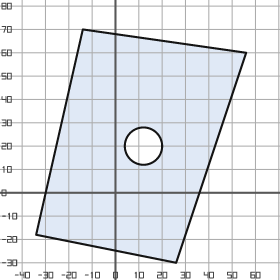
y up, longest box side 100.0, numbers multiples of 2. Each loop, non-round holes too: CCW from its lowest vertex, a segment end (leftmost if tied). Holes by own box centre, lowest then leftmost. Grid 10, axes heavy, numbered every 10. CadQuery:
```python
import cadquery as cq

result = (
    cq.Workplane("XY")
    .moveTo(26.0, -30.0)
    .lineTo(56.0, 60.0)
    .lineTo(-14.0, 70.0)
    .lineTo(-34.0, -18.0)
    .close()
    .moveTo(12.0, 20.0)
    .circle(8.0)
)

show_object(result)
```